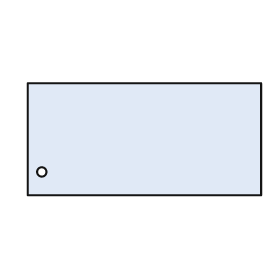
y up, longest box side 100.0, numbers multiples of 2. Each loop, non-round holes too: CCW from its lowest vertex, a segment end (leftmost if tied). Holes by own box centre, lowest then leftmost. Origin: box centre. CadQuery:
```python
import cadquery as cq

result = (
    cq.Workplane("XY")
    .moveTo(-50.0, -24.0)
    .lineTo(50.0, -24.0)
    .lineTo(50.0, 24.0)
    .lineTo(-50.0, 24.0)
    .close()
    .moveTo(-44.0, -14.0)
    .circle(2.0)
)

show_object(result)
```